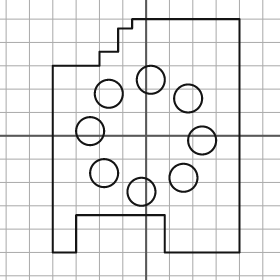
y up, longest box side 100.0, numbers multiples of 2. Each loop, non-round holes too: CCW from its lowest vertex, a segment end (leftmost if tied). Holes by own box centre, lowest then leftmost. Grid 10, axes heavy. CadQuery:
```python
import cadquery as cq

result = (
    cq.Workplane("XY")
    .moveTo(-40.0, -50.0)
    .lineTo(-30.0, -50.0)
    .lineTo(-30.0, -34.0)
    .lineTo(8.0, -34.0)
    .lineTo(8.0, -50.0)
    .lineTo(40.0, -50.0)
    .lineTo(40.0, 50.0)
    .lineTo(-6.0, 50.0)
    .lineTo(-6.0, 46.0)
    .lineTo(-12.0, 46.0)
    .lineTo(-12.0, 36.0)
    .lineTo(-20.0, 36.0)
    .lineTo(-20.0, 30.0)
    .lineTo(-40.0, 30.0)
    .close()
    .moveTo(-2.0, -24.0)
    .circle(6.0)
    .moveTo(16.0, -18.0)
    .circle(6.0)
    .moveTo(-18.0, -16.0)
    .circle(6.0)
    .moveTo(24.0, -2.0)
    .circle(6.0)
    .moveTo(-24.0, 2.0)
    .circle(6.0)
    .moveTo(18.0, 16.0)
    .circle(6.0)
    .moveTo(-16.0, 18.0)
    .circle(6.0)
    .moveTo(2.0, 24.0)
    .circle(6.0)
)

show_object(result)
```